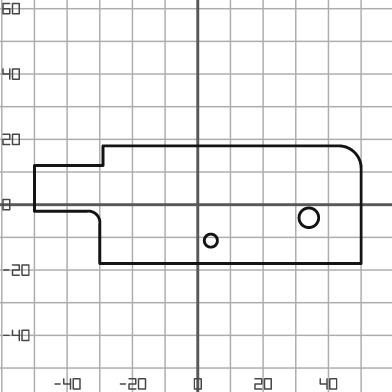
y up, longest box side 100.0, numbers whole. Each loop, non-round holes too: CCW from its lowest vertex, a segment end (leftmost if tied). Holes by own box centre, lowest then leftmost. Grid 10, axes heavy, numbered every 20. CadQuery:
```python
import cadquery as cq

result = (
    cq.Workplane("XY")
    .moveTo(-30.0, -18.0)
    .lineTo(50.0, -18.0)
    .lineTo(50.0, 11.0)
    .threePointArc((48.0, 16.0), (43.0, 18.0))
    .lineTo(-29.0, 18.0)
    .lineTo(-29.0, 12.0)
    .lineTo(-50.0, 12.0)
    .lineTo(-50.0, -2.0)
    .lineTo(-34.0, -2.0)
    .threePointArc((-31.0, -3.0), (-30.0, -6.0))
    .close()
    .moveTo(4.0, -11.0)
    .circle(2.0)
    .moveTo(34.0, -4.0)
    .circle(3.0)
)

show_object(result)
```